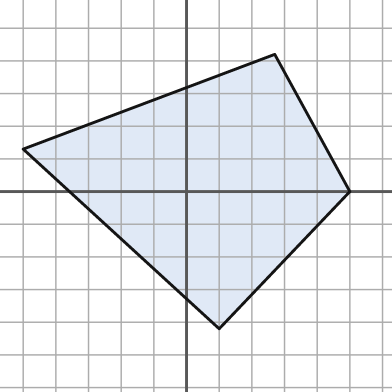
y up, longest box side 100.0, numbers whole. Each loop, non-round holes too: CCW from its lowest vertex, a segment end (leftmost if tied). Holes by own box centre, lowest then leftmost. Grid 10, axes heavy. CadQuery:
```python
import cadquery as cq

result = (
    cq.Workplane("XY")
    .moveTo(10.0, -42.0)
    .lineTo(50.0, 0.0)
    .lineTo(27.0, 42.0)
    .lineTo(-50.0, 13.0)
    .close()
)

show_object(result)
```